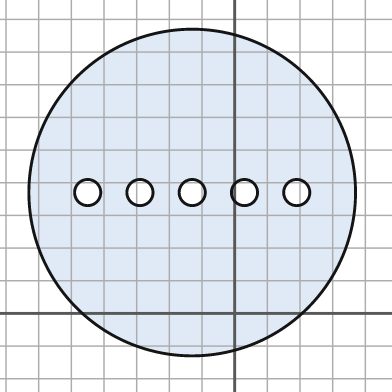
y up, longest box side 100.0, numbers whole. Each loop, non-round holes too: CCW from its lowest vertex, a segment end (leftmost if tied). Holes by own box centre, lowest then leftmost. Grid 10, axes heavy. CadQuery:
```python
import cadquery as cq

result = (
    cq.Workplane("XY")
    .moveTo(-13.0, 37.0)
    .circle(50.0)
    .moveTo(-45.0, 37.0)
    .circle(4.0)
    .moveTo(-29.0, 37.0)
    .circle(4.0)
    .moveTo(-13.0, 37.0)
    .circle(4.0)
    .moveTo(3.0, 37.0)
    .circle(4.0)
    .moveTo(19.0, 37.0)
    .circle(4.0)
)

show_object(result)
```